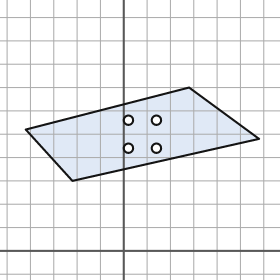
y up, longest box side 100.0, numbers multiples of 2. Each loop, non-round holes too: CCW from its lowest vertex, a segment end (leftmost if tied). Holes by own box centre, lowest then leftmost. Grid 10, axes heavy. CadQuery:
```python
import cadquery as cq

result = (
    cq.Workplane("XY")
    .moveTo(-22.0, 30.0)
    .lineTo(58.0, 48.0)
    .lineTo(28.0, 70.0)
    .lineTo(-42.0, 52.0)
    .close()
    .moveTo(2.0, 44.0)
    .circle(2.0)
    .moveTo(14.0, 44.0)
    .circle(2.0)
    .moveTo(2.0, 56.0)
    .circle(2.0)
    .moveTo(14.0, 56.0)
    .circle(2.0)
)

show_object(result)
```